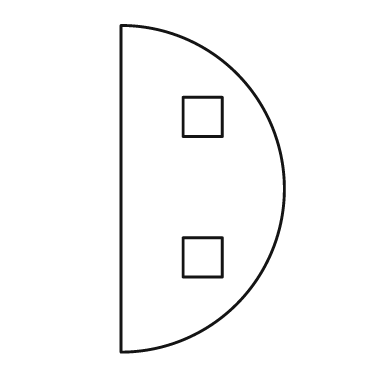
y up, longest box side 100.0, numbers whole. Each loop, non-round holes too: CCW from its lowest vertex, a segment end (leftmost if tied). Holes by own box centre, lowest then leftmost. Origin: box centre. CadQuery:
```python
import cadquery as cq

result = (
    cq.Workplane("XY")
    .moveTo(-25.0, -50.0)
    .threePointArc((25.0, 0.0), (-25.0, 50.0))
    .close()
    .moveTo(-6.0, -27.0)
    .lineTo(6.0, -27.0)
    .lineTo(6.0, -15.0)
    .lineTo(-6.0, -15.0)
    .close()
    .moveTo(-6.0, 16.0)
    .lineTo(6.0, 16.0)
    .lineTo(6.0, 28.0)
    .lineTo(-6.0, 28.0)
    .close()
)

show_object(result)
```